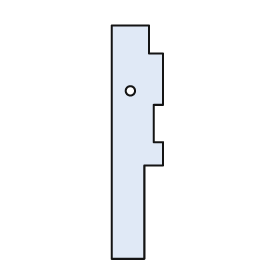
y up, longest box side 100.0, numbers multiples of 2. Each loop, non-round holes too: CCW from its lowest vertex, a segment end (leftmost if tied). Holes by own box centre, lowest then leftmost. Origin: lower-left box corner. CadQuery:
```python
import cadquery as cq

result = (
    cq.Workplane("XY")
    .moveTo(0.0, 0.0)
    .lineTo(14.0, 0.0)
    .lineTo(14.0, 40.0)
    .lineTo(22.0, 40.0)
    .lineTo(22.0, 50.0)
    .lineTo(18.0, 50.0)
    .lineTo(18.0, 66.0)
    .lineTo(22.0, 66.0)
    .lineTo(22.0, 88.0)
    .lineTo(16.0, 88.0)
    .lineTo(16.0, 100.0)
    .lineTo(0.0, 100.0)
    .close()
    .moveTo(8.0, 72.0)
    .circle(2.0)
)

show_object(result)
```